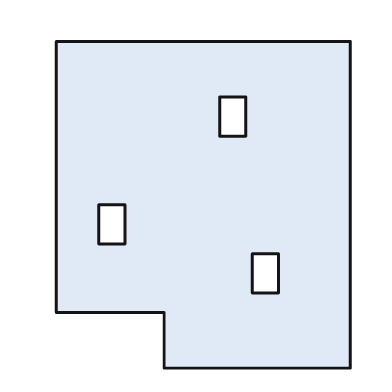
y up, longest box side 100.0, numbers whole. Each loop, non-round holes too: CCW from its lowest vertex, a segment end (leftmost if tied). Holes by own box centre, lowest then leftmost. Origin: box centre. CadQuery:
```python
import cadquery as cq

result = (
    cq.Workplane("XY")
    .moveTo(-12.0, -50.0)
    .lineTo(45.0, -50.0)
    .lineTo(45.0, 50.0)
    .lineTo(-45.0, 50.0)
    .lineTo(-45.0, -33.0)
    .lineTo(-12.0, -33.0)
    .close()
    .moveTo(15.0, -27.0)
    .lineTo(23.0, -27.0)
    .lineTo(23.0, -15.0)
    .lineTo(15.0, -15.0)
    .close()
    .moveTo(-32.0, -12.0)
    .lineTo(-24.0, -12.0)
    .lineTo(-24.0, 0.0)
    .lineTo(-32.0, 0.0)
    .close()
    .moveTo(5.0, 21.0)
    .lineTo(13.0, 21.0)
    .lineTo(13.0, 33.0)
    .lineTo(5.0, 33.0)
    .close()
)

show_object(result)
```